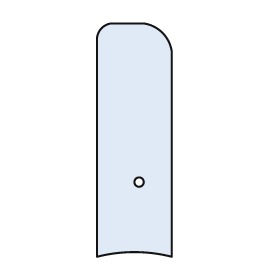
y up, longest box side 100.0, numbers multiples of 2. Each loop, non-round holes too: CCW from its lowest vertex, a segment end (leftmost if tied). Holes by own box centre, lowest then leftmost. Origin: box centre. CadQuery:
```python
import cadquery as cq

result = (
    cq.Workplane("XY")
    .moveTo(-16.0, -50.0)
    .threePointArc((0.0, -48.0), (16.0, -50.0))
    .lineTo(16.0, 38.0)
    .threePointArc((12.0, 46.0), (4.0, 50.0))
    .lineTo(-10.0, 50.0)
    .threePointArc((-14.0, 48.0), (-16.0, 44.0))
    .close()
    .moveTo(2.0, -18.0)
    .circle(2.0)
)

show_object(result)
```